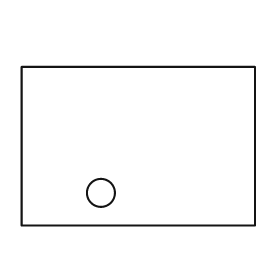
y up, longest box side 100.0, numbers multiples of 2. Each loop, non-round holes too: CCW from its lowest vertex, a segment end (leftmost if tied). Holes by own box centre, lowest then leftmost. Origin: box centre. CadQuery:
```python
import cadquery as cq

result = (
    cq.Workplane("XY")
    .moveTo(-50.0, -34.0)
    .lineTo(50.0, -34.0)
    .lineTo(50.0, 34.0)
    .lineTo(-50.0, 34.0)
    .close()
    .moveTo(-16.0, -20.0)
    .circle(6.0)
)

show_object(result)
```